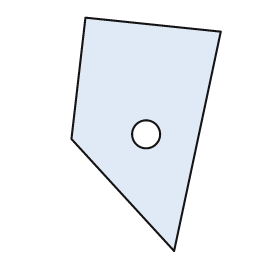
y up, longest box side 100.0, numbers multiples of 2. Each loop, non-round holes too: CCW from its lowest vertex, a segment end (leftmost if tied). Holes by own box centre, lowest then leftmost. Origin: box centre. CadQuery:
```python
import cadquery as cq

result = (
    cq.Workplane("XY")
    .moveTo(12.0, -50.0)
    .lineTo(32.0, 44.0)
    .lineTo(-26.0, 50.0)
    .lineTo(-32.0, -2.0)
    .close()
    .moveTo(0.0, 0.0)
    .circle(6.0)
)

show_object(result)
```